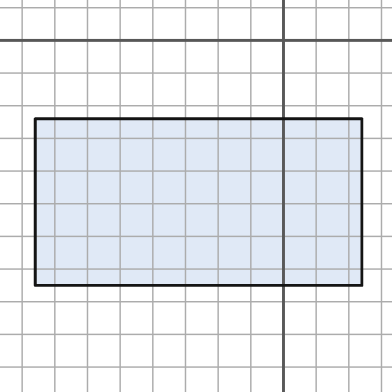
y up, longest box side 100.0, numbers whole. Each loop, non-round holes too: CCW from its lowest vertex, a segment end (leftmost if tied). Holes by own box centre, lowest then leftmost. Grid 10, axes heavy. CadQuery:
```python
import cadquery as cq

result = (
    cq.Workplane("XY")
    .moveTo(-76.0, -75.0)
    .lineTo(24.0, -75.0)
    .lineTo(24.0, -24.0)
    .lineTo(-76.0, -24.0)
    .close()
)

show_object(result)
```